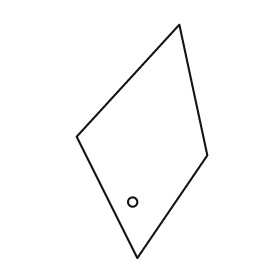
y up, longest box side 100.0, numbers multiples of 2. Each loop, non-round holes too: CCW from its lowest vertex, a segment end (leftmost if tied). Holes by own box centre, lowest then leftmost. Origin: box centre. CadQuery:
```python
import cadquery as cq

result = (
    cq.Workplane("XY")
    .moveTo(-2.0, -50.0)
    .lineTo(28.0, -6.0)
    .lineTo(16.0, 50.0)
    .lineTo(-28.0, 2.0)
    .close()
    .moveTo(-4.0, -26.0)
    .circle(2.0)
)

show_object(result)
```